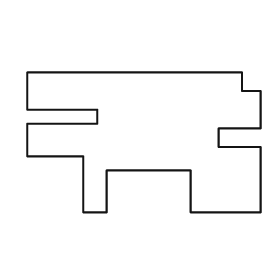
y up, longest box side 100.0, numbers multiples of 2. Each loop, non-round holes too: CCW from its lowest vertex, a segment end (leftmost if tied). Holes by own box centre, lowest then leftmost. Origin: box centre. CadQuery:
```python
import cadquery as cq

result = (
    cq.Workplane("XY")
    .moveTo(-26.0, -30.0)
    .lineTo(-16.0, -30.0)
    .lineTo(-16.0, -12.0)
    .lineTo(20.0, -12.0)
    .lineTo(20.0, -30.0)
    .lineTo(50.0, -30.0)
    .lineTo(50.0, -2.0)
    .lineTo(32.0, -2.0)
    .lineTo(32.0, 6.0)
    .lineTo(50.0, 6.0)
    .lineTo(50.0, 22.0)
    .lineTo(42.0, 22.0)
    .lineTo(42.0, 30.0)
    .lineTo(-50.0, 30.0)
    .lineTo(-50.0, 14.0)
    .lineTo(-20.0, 14.0)
    .lineTo(-20.0, 8.0)
    .lineTo(-50.0, 8.0)
    .lineTo(-50.0, -6.0)
    .lineTo(-26.0, -6.0)
    .close()
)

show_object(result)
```